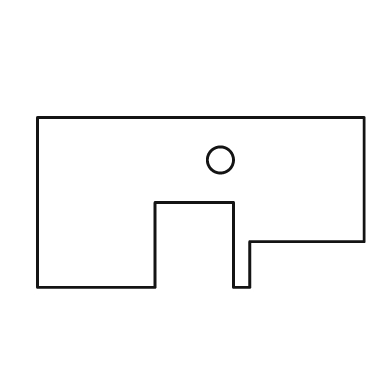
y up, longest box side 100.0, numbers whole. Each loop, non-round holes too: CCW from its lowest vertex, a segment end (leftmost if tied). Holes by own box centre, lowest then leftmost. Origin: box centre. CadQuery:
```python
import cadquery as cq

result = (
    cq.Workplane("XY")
    .moveTo(-50.0, -26.0)
    .lineTo(-14.0, -26.0)
    .lineTo(-14.0, 0.0)
    .lineTo(10.0, 0.0)
    .lineTo(10.0, -26.0)
    .lineTo(15.0, -26.0)
    .lineTo(15.0, -12.0)
    .lineTo(50.0, -12.0)
    .lineTo(50.0, 26.0)
    .lineTo(-50.0, 26.0)
    .close()
    .moveTo(6.0, 13.0)
    .circle(4.0)
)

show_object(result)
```